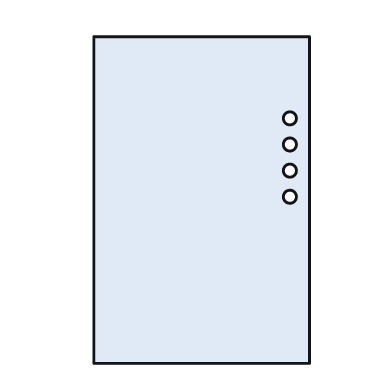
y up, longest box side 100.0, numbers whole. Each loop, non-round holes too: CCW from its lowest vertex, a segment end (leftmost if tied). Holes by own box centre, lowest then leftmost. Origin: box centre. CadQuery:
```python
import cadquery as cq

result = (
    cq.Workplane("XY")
    .moveTo(-33.0, -50.0)
    .lineTo(33.0, -50.0)
    .lineTo(33.0, 50.0)
    .lineTo(-33.0, 50.0)
    .close()
    .moveTo(27.0, 1.0)
    .circle(2.0)
    .moveTo(27.0, 9.0)
    .circle(2.0)
    .moveTo(27.0, 17.0)
    .circle(2.0)
    .moveTo(27.0, 25.0)
    .circle(2.0)
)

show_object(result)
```